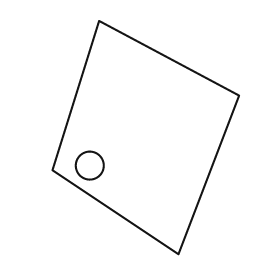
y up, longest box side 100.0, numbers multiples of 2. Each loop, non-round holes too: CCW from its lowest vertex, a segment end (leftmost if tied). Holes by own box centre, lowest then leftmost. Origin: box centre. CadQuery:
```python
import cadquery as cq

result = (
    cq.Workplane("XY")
    .moveTo(14.0, -50.0)
    .lineTo(40.0, 18.0)
    .lineTo(-20.0, 50.0)
    .lineTo(-40.0, -14.0)
    .close()
    .moveTo(-24.0, -12.0)
    .circle(6.0)
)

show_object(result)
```